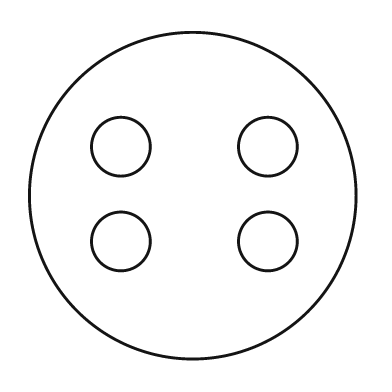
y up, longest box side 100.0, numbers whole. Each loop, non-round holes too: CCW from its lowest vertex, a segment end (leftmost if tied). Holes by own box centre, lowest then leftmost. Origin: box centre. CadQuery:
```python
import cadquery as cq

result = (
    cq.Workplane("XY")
    .moveTo(0.0, 0.0)
    .circle(50.0)
    .moveTo(-22.0, -14.0)
    .circle(9.0)
    .moveTo(23.0, -14.0)
    .circle(9.0)
    .moveTo(-22.0, 15.0)
    .circle(9.0)
    .moveTo(23.0, 15.0)
    .circle(9.0)
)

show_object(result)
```